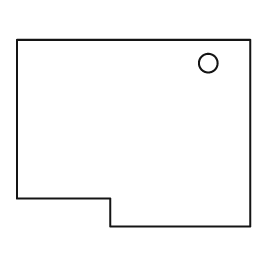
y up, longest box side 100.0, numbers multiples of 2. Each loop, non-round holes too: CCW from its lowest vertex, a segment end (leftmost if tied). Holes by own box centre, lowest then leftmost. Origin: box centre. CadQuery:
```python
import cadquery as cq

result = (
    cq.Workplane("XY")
    .moveTo(-10.0, -40.0)
    .lineTo(50.0, -40.0)
    .lineTo(50.0, 40.0)
    .lineTo(-50.0, 40.0)
    .lineTo(-50.0, -28.0)
    .lineTo(-10.0, -28.0)
    .close()
    .moveTo(32.0, 30.0)
    .circle(4.0)
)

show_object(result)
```